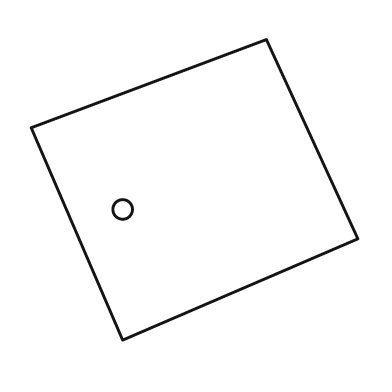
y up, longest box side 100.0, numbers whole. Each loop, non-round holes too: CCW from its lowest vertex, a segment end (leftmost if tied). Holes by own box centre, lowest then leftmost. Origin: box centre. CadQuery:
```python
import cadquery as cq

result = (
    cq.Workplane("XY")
    .moveTo(-22.0, -46.0)
    .lineTo(50.0, -15.0)
    .lineTo(22.0, 46.0)
    .lineTo(-50.0, 19.0)
    .close()
    .moveTo(-22.0, -6.0)
    .circle(3.0)
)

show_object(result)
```